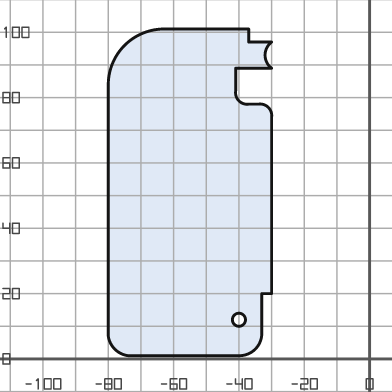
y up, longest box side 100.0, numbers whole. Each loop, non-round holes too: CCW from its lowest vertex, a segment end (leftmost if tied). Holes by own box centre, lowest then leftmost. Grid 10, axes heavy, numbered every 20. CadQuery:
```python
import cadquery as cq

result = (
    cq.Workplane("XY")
    .moveTo(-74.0, 1.0)
    .lineTo(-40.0, 1.0)
    .threePointArc((-35.0, 3.0), (-33.0, 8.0))
    .lineTo(-33.0, 20.0)
    .lineTo(-30.0, 20.0)
    .lineTo(-30.0, 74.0)
    .threePointArc((-31.0, 77.0), (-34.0, 78.0))
    .lineTo(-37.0, 78.0)
    .threePointArc((-40.0, 79.0), (-41.0, 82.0))
    .lineTo(-41.0, 89.0)
    .lineTo(-30.0, 89.0)
    .threePointArc((-32.0, 93.0), (-30.0, 97.0))
    .lineTo(-37.0, 97.0)
    .lineTo(-37.0, 101.0)
    .lineTo(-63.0, 101.0)
    .threePointArc((-75.0, 96.0), (-80.0, 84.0))
    .lineTo(-80.0, 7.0)
    .threePointArc((-78.0, 3.0), (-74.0, 1.0))
    .close()
    .moveTo(-40.0, 12.0)
    .circle(2.0)
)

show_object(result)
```